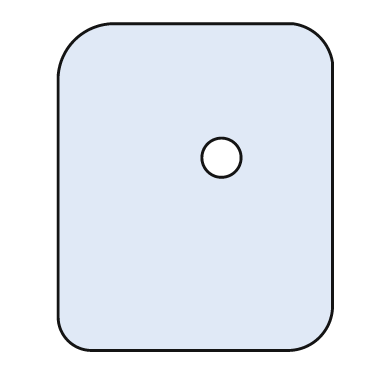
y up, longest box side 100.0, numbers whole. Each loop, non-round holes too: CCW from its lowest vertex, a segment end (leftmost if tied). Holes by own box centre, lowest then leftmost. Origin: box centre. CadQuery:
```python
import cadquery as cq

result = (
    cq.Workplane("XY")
    .moveTo(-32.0, -50.0)
    .lineTo(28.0, -50.0)
    .threePointArc((38.0, -46.0), (42.0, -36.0))
    .lineTo(42.0, 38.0)
    .threePointArc((38.0, 46.0), (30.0, 50.0))
    .lineTo(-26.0, 50.0)
    .threePointArc((-37.0, 45.0), (-42.0, 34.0))
    .lineTo(-42.0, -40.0)
    .threePointArc((-39.0, -47.0), (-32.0, -50.0))
    .close()
    .moveTo(8.0, 9.0)
    .circle(6.0)
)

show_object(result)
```